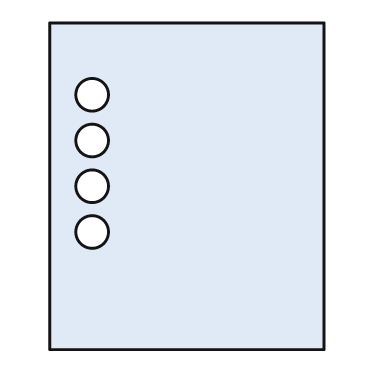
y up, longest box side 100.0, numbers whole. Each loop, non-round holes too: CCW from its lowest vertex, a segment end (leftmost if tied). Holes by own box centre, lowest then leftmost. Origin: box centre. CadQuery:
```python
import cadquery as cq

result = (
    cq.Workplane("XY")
    .moveTo(-42.0, -50.0)
    .lineTo(42.0, -50.0)
    .lineTo(42.0, 50.0)
    .lineTo(-42.0, 50.0)
    .close()
    .moveTo(-29.0, -14.0)
    .circle(5.0)
    .moveTo(-29.0, 0.0)
    .circle(5.0)
    .moveTo(-29.0, 14.0)
    .circle(5.0)
    .moveTo(-29.0, 28.0)
    .circle(5.0)
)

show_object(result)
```